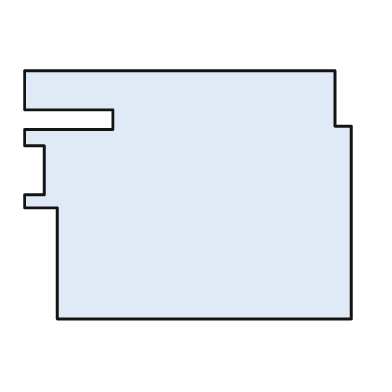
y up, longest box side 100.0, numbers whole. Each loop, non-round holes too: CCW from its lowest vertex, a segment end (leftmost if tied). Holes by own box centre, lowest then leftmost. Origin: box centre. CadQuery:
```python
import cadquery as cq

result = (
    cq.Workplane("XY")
    .moveTo(-40.0, -38.0)
    .lineTo(50.0, -38.0)
    .lineTo(50.0, 21.0)
    .lineTo(45.0, 21.0)
    .lineTo(45.0, 38.0)
    .lineTo(-50.0, 38.0)
    .lineTo(-50.0, 26.0)
    .lineTo(-23.0, 26.0)
    .lineTo(-23.0, 20.0)
    .lineTo(-50.0, 20.0)
    .lineTo(-50.0, 15.0)
    .lineTo(-44.0, 15.0)
    .lineTo(-44.0, 0.0)
    .lineTo(-50.0, 0.0)
    .lineTo(-50.0, -4.0)
    .lineTo(-40.0, -4.0)
    .close()
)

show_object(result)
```